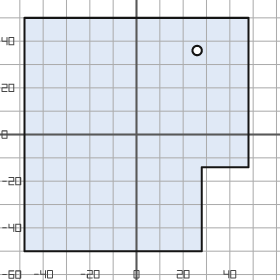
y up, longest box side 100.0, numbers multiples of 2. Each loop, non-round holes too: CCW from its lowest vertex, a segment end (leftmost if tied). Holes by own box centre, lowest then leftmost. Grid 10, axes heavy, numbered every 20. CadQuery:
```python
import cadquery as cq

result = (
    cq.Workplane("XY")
    .moveTo(-48.0, -50.0)
    .lineTo(28.0, -50.0)
    .lineTo(28.0, -14.0)
    .lineTo(48.0, -14.0)
    .lineTo(48.0, 50.0)
    .lineTo(-48.0, 50.0)
    .close()
    .moveTo(26.0, 36.0)
    .circle(2.0)
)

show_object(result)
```